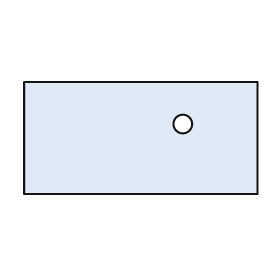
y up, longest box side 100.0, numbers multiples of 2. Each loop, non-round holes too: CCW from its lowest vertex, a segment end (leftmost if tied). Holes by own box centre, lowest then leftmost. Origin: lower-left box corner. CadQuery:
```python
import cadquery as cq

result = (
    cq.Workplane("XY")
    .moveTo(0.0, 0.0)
    .lineTo(100.0, 0.0)
    .lineTo(100.0, 48.0)
    .lineTo(0.0, 48.0)
    .close()
    .moveTo(68.0, 30.0)
    .circle(4.0)
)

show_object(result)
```